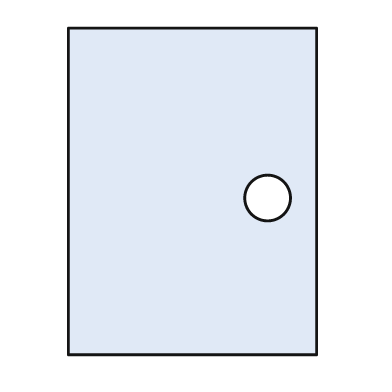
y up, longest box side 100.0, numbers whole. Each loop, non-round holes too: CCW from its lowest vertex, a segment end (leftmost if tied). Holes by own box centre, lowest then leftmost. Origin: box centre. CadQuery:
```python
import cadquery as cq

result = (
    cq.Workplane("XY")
    .moveTo(-38.0, -50.0)
    .lineTo(38.0, -50.0)
    .lineTo(38.0, 50.0)
    .lineTo(-38.0, 50.0)
    .close()
    .moveTo(23.0, -2.0)
    .circle(7.0)
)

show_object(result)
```